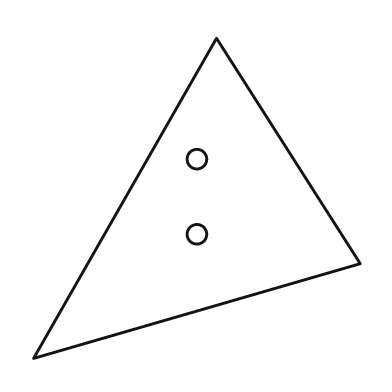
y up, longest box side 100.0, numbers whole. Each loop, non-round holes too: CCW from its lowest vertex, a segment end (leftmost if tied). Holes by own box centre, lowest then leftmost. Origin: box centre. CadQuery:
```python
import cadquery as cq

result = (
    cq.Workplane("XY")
    .moveTo(-50.0, -49.0)
    .lineTo(50.0, -20.0)
    .lineTo(6.0, 49.0)
    .close()
    .moveTo(0.0, -11.0)
    .circle(3.0)
    .moveTo(0.0, 12.0)
    .circle(3.0)
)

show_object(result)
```